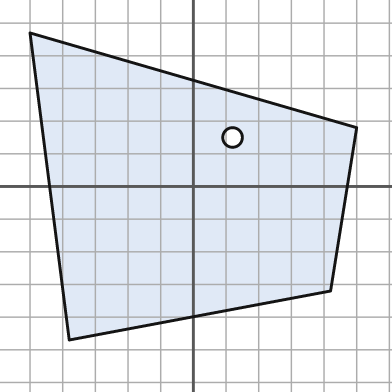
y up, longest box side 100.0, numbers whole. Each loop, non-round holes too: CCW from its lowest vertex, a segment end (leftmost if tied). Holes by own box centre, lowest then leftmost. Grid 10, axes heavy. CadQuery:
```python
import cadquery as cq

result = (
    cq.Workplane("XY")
    .moveTo(-38.0, -47.0)
    .lineTo(42.0, -32.0)
    .lineTo(50.0, 18.0)
    .lineTo(-50.0, 47.0)
    .close()
    .moveTo(12.0, 15.0)
    .circle(3.0)
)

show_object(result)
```